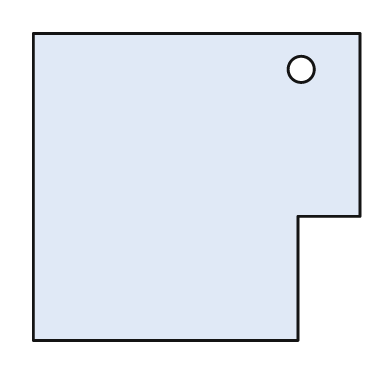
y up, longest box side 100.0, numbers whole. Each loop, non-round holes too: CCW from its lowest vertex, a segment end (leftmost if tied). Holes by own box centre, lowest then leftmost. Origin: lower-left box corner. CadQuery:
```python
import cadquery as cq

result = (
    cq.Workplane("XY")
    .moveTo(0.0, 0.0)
    .lineTo(81.0, 0.0)
    .lineTo(81.0, 38.0)
    .lineTo(100.0, 38.0)
    .lineTo(100.0, 94.0)
    .lineTo(0.0, 94.0)
    .close()
    .moveTo(82.0, 83.0)
    .circle(4.0)
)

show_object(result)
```